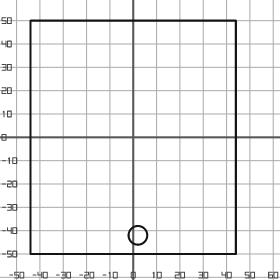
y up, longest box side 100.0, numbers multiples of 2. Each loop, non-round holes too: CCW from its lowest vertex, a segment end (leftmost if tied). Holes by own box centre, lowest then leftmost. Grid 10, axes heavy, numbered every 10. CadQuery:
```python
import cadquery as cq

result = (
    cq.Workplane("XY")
    .moveTo(-44.0, -50.0)
    .lineTo(44.0, -50.0)
    .lineTo(44.0, 50.0)
    .lineTo(-44.0, 50.0)
    .close()
    .moveTo(2.0, -42.0)
    .circle(4.0)
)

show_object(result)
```